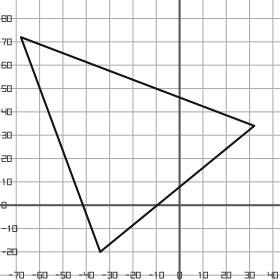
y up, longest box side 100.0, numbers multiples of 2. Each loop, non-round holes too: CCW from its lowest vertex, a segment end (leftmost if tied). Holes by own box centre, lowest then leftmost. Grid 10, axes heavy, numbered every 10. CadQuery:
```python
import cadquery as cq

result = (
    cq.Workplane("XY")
    .moveTo(-34.0, -20.0)
    .lineTo(32.0, 34.0)
    .lineTo(-68.0, 72.0)
    .close()
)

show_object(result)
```